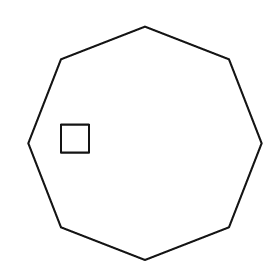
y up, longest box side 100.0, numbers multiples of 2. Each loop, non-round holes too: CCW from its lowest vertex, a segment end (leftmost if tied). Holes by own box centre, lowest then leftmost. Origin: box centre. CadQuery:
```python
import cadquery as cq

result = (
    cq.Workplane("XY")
    .moveTo(0.0, -50.0)
    .lineTo(36.0, -36.0)
    .lineTo(50.0, 0.0)
    .lineTo(36.0, 36.0)
    .lineTo(0.0, 50.0)
    .lineTo(-36.0, 36.0)
    .lineTo(-50.0, 0.0)
    .lineTo(-36.0, -36.0)
    .close()
    .moveTo(-36.0, -4.0)
    .lineTo(-24.0, -4.0)
    .lineTo(-24.0, 8.0)
    .lineTo(-36.0, 8.0)
    .close()
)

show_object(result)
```